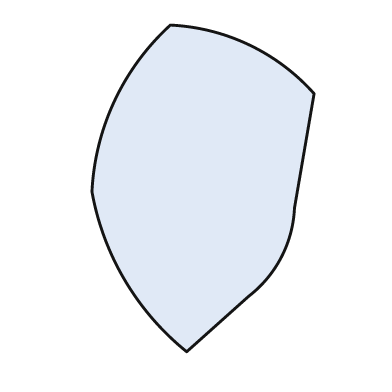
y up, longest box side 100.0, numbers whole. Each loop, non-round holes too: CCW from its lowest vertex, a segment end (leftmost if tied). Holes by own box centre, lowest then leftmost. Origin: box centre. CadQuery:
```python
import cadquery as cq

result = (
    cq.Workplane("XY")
    .moveTo(-5.0, -50.0)
    .lineTo(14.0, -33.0)
    .threePointArc((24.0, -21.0), (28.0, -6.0))
    .lineTo(34.0, 29.0)
    .threePointArc((14.0, 44.0), (-10.0, 50.0))
    .threePointArc((-27.0, 27.0), (-34.0, -1.0))
    .threePointArc((-24.0, -28.0), (-5.0, -50.0))
    .close()
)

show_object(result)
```